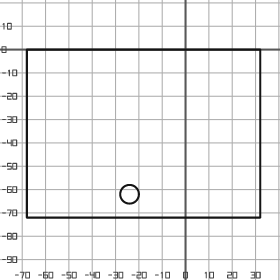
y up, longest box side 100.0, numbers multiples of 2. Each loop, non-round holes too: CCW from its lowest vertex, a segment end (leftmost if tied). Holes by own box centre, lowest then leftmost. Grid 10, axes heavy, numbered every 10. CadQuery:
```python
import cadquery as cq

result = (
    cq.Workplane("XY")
    .moveTo(-68.0, -72.0)
    .lineTo(32.0, -72.0)
    .lineTo(32.0, 0.0)
    .lineTo(-68.0, 0.0)
    .close()
    .moveTo(-24.0, -62.0)
    .circle(4.0)
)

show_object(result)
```